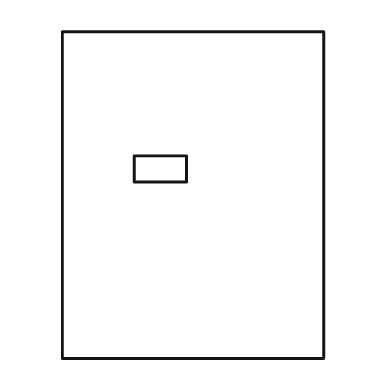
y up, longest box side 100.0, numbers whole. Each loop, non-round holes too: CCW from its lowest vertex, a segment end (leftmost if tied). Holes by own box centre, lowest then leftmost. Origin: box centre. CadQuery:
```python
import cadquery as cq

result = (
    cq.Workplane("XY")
    .moveTo(-40.0, -50.0)
    .lineTo(40.0, -50.0)
    .lineTo(40.0, 50.0)
    .lineTo(-40.0, 50.0)
    .close()
    .moveTo(-18.0, 4.0)
    .lineTo(-2.0, 4.0)
    .lineTo(-2.0, 12.0)
    .lineTo(-18.0, 12.0)
    .close()
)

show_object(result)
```